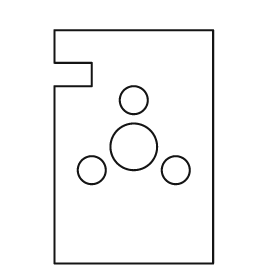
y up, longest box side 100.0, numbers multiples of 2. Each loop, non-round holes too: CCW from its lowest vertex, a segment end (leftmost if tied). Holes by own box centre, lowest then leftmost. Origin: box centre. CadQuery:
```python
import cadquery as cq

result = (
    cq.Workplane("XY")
    .moveTo(-34.0, -50.0)
    .lineTo(34.0, -50.0)
    .lineTo(34.0, 50.0)
    .lineTo(-34.0, 50.0)
    .lineTo(-34.0, 36.0)
    .lineTo(-18.0, 36.0)
    .lineTo(-18.0, 26.0)
    .lineTo(-34.0, 26.0)
    .close()
    .moveTo(-18.0, -10.0)
    .circle(6.0)
    .moveTo(18.0, -10.0)
    .circle(6.0)
    .moveTo(0.0, 0.0)
    .circle(10.0)
    .moveTo(0.0, 20.0)
    .circle(6.0)
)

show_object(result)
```